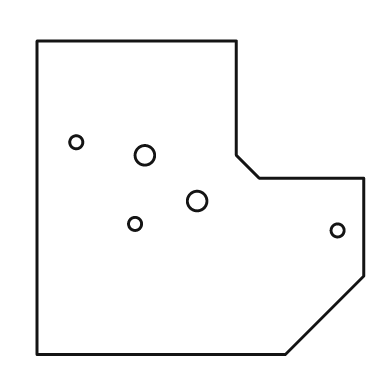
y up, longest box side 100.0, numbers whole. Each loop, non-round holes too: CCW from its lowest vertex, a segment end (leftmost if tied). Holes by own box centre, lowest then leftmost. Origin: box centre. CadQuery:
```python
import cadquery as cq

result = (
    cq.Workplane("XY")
    .moveTo(-50.0, -48.0)
    .lineTo(26.0, -48.0)
    .lineTo(50.0, -24.0)
    .lineTo(50.0, 6.0)
    .lineTo(18.0, 6.0)
    .lineTo(11.0, 13.0)
    .lineTo(11.0, 48.0)
    .lineTo(-50.0, 48.0)
    .close()
    .moveTo(42.0, -10.0)
    .circle(2.0)
    .moveTo(-20.0, -8.0)
    .circle(2.0)
    .moveTo(-1.0, -1.0)
    .circle(3.0)
    .moveTo(-17.0, 13.0)
    .circle(3.0)
    .moveTo(-38.0, 17.0)
    .circle(2.0)
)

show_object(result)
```